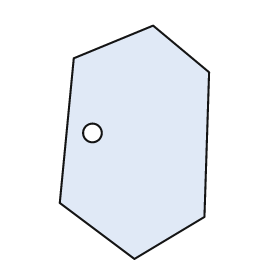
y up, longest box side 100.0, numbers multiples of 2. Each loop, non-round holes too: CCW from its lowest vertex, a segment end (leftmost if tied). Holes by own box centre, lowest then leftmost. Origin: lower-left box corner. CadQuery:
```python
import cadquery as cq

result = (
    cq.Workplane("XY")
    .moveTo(32.0, 0.0)
    .lineTo(62.0, 18.0)
    .lineTo(64.0, 80.0)
    .lineTo(40.0, 100.0)
    .lineTo(6.0, 86.0)
    .lineTo(0.0, 24.0)
    .close()
    .moveTo(14.0, 54.0)
    .circle(4.0)
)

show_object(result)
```